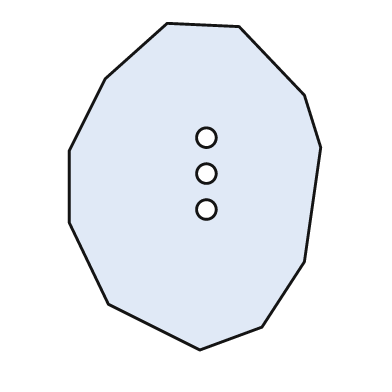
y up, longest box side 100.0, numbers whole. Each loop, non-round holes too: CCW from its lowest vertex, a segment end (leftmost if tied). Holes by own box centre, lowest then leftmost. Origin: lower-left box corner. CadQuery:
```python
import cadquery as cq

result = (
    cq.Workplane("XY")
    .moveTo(40.0, 0.0)
    .lineTo(59.0, 7.0)
    .lineTo(72.0, 27.0)
    .lineTo(77.0, 62.0)
    .lineTo(72.0, 78.0)
    .lineTo(52.0, 99.0)
    .lineTo(30.0, 100.0)
    .lineTo(11.0, 83.0)
    .lineTo(0.0, 61.0)
    .lineTo(0.0, 39.0)
    .lineTo(12.0, 14.0)
    .close()
    .moveTo(42.0, 43.0)
    .circle(3.0)
    .moveTo(42.0, 54.0)
    .circle(3.0)
    .moveTo(42.0, 65.0)
    .circle(3.0)
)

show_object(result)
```